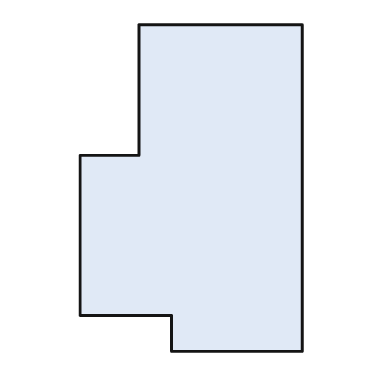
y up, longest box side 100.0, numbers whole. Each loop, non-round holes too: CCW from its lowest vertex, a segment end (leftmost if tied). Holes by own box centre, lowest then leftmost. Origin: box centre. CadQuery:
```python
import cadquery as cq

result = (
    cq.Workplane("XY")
    .moveTo(-6.0, -50.0)
    .lineTo(34.0, -50.0)
    .lineTo(34.0, 50.0)
    .lineTo(-16.0, 50.0)
    .lineTo(-16.0, 10.0)
    .lineTo(-34.0, 10.0)
    .lineTo(-34.0, -39.0)
    .lineTo(-6.0, -39.0)
    .close()
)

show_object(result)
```